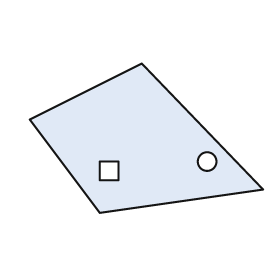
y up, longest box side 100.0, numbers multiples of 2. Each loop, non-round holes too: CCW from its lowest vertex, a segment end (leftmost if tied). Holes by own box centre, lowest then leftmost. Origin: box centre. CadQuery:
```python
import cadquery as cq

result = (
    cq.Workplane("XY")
    .moveTo(-20.0, -32.0)
    .lineTo(50.0, -22.0)
    .lineTo(-2.0, 32.0)
    .lineTo(-50.0, 8.0)
    .close()
    .moveTo(-20.0, -18.0)
    .lineTo(-12.0, -18.0)
    .lineTo(-12.0, -10.0)
    .lineTo(-20.0, -10.0)
    .close()
    .moveTo(26.0, -10.0)
    .circle(4.0)
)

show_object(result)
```